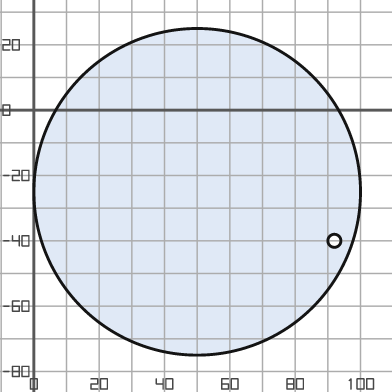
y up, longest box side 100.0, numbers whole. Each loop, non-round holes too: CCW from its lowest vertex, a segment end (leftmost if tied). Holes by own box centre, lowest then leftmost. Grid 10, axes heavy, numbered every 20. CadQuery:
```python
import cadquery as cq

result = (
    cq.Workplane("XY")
    .moveTo(50.0, -25.0)
    .circle(50.0)
    .moveTo(92.0, -40.0)
    .circle(2.0)
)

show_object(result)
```